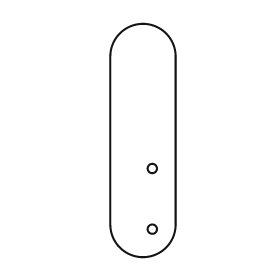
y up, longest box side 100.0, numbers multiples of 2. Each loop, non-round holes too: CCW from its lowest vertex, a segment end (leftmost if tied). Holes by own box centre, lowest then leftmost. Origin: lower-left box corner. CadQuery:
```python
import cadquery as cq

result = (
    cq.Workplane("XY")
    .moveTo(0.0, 14.0)
    .threePointArc((14.0, 0.0), (28.0, 14.0))
    .lineTo(28.0, 86.0)
    .threePointArc((14.0, 100.0), (0.0, 86.0))
    .close()
    .moveTo(18.0, 12.0)
    .circle(2.0)
    .moveTo(18.0, 38.0)
    .circle(2.0)
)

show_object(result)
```